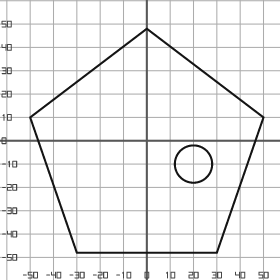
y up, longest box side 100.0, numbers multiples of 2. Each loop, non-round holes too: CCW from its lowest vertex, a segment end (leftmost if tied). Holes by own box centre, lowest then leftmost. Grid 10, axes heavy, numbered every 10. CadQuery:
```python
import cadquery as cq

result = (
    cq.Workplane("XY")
    .moveTo(-30.0, -48.0)
    .lineTo(30.0, -48.0)
    .lineTo(50.0, 10.0)
    .lineTo(0.0, 48.0)
    .lineTo(-50.0, 10.0)
    .close()
    .moveTo(20.0, -10.0)
    .circle(8.0)
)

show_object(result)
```